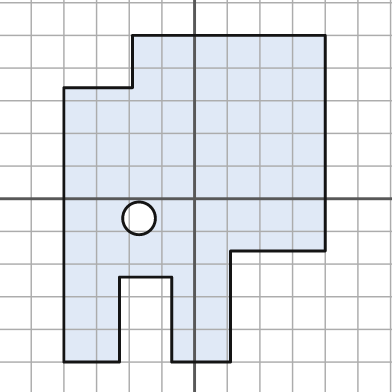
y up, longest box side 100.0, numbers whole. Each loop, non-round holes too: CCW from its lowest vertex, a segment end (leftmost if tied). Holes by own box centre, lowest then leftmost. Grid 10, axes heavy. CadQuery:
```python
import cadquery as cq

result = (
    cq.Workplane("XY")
    .moveTo(-40.0, -50.0)
    .lineTo(-23.0, -50.0)
    .lineTo(-23.0, -24.0)
    .lineTo(-7.0, -24.0)
    .lineTo(-7.0, -50.0)
    .lineTo(11.0, -50.0)
    .lineTo(11.0, -16.0)
    .lineTo(40.0, -16.0)
    .lineTo(40.0, 50.0)
    .lineTo(-19.0, 50.0)
    .lineTo(-19.0, 34.0)
    .lineTo(-40.0, 34.0)
    .close()
    .moveTo(-17.0, -6.0)
    .circle(5.0)
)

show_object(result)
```